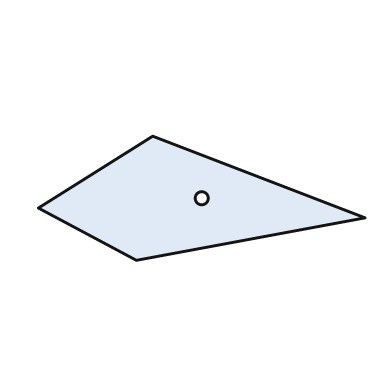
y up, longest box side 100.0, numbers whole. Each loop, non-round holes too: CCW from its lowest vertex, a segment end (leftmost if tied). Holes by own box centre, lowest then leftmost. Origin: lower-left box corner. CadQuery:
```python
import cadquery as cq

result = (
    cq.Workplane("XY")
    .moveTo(30.0, 0.0)
    .lineTo(100.0, 13.0)
    .lineTo(35.0, 38.0)
    .lineTo(0.0, 16.0)
    .close()
    .moveTo(50.0, 19.0)
    .circle(2.0)
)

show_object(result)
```